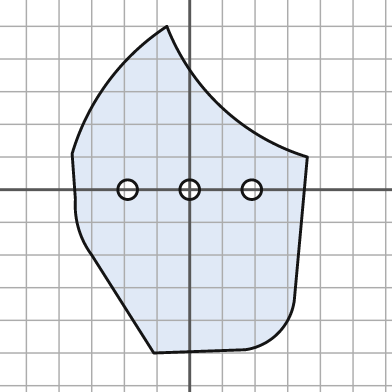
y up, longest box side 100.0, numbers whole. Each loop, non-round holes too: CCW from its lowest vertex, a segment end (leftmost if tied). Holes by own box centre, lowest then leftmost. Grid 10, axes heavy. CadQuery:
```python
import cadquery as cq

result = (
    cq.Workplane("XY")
    .moveTo(-11.0, -50.0)
    .lineTo(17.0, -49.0)
    .threePointArc((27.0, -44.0), (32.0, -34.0))
    .lineTo(36.0, 10.0)
    .threePointArc((10.0, 25.0), (-7.0, 50.0))
    .threePointArc((-25.0, 33.0), (-36.0, 11.0))
    .lineTo(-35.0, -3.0)
    .threePointArc((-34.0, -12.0), (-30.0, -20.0))
    .close()
    .moveTo(-19.0, 0.0)
    .circle(3.0)
    .moveTo(0.0, 0.0)
    .circle(3.0)
    .moveTo(19.0, 0.0)
    .circle(3.0)
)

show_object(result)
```